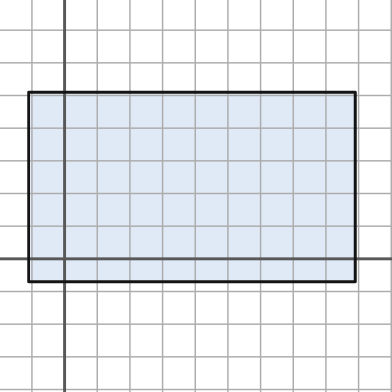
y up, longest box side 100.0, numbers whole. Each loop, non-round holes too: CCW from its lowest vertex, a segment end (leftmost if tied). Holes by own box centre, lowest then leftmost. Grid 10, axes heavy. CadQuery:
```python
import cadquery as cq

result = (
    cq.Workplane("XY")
    .moveTo(-11.0, -7.0)
    .lineTo(89.0, -7.0)
    .lineTo(89.0, 51.0)
    .lineTo(-11.0, 51.0)
    .close()
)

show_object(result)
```